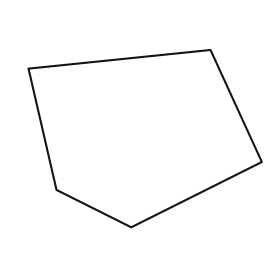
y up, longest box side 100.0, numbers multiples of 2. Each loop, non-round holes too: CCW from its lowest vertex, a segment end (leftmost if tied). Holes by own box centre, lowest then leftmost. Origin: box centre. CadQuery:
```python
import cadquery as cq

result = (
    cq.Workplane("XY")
    .moveTo(-6.0, -38.0)
    .lineTo(50.0, -10.0)
    .lineTo(28.0, 38.0)
    .lineTo(-50.0, 30.0)
    .lineTo(-38.0, -22.0)
    .close()
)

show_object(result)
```